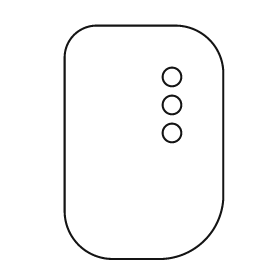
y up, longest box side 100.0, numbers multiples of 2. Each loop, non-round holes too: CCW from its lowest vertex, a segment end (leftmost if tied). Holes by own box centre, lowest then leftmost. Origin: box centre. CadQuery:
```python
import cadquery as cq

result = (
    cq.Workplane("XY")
    .moveTo(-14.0, -50.0)
    .lineTo(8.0, -50.0)
    .threePointArc((26.0, -42.0), (34.0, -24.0))
    .lineTo(34.0, 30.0)
    .threePointArc((28.0, 44.0), (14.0, 50.0))
    .lineTo(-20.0, 50.0)
    .threePointArc((-30.0, 46.0), (-34.0, 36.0))
    .lineTo(-34.0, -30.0)
    .threePointArc((-28.0, -44.0), (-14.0, -50.0))
    .close()
    .moveTo(12.0, 4.0)
    .circle(4.0)
    .moveTo(12.0, 16.0)
    .circle(4.0)
    .moveTo(12.0, 28.0)
    .circle(4.0)
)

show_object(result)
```